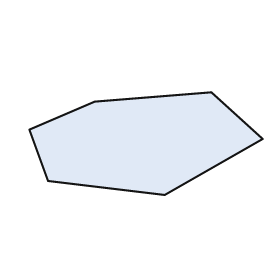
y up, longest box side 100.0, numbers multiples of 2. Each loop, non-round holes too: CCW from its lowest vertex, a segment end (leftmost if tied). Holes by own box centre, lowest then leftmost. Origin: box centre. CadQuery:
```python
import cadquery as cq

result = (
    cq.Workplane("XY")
    .moveTo(8.0, -22.0)
    .lineTo(50.0, 2.0)
    .lineTo(28.0, 22.0)
    .lineTo(-22.0, 18.0)
    .lineTo(-50.0, 6.0)
    .lineTo(-42.0, -16.0)
    .close()
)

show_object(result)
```